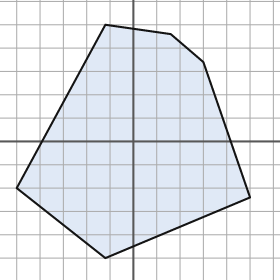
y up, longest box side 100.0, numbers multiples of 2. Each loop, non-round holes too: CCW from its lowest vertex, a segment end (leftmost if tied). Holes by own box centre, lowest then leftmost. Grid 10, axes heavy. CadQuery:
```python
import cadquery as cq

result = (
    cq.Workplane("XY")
    .moveTo(-12.0, -50.0)
    .lineTo(50.0, -24.0)
    .lineTo(30.0, 34.0)
    .lineTo(16.0, 46.0)
    .lineTo(-12.0, 50.0)
    .lineTo(-50.0, -20.0)
    .close()
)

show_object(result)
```